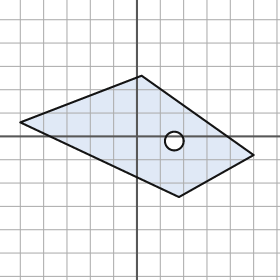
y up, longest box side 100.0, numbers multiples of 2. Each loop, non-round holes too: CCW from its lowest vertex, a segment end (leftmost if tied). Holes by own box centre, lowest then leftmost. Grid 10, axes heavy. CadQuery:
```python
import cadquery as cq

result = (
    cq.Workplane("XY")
    .moveTo(18.0, -26.0)
    .lineTo(50.0, -8.0)
    .lineTo(2.0, 26.0)
    .lineTo(-50.0, 6.0)
    .close()
    .moveTo(16.0, -2.0)
    .circle(4.0)
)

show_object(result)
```